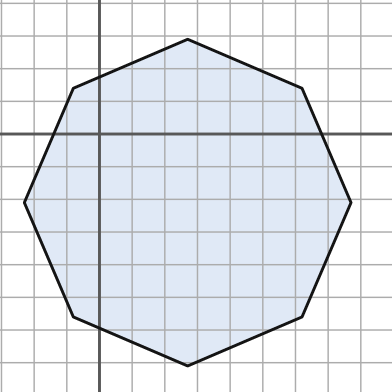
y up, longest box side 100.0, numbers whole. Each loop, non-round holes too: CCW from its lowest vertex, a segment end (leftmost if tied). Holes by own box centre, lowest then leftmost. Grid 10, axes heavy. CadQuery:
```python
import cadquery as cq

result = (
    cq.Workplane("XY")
    .moveTo(27.0, -71.0)
    .lineTo(62.0, -56.0)
    .lineTo(77.0, -21.0)
    .lineTo(62.0, 14.0)
    .lineTo(27.0, 29.0)
    .lineTo(-8.0, 14.0)
    .lineTo(-23.0, -21.0)
    .lineTo(-8.0, -56.0)
    .close()
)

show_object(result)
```